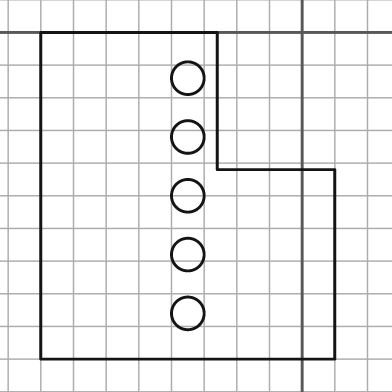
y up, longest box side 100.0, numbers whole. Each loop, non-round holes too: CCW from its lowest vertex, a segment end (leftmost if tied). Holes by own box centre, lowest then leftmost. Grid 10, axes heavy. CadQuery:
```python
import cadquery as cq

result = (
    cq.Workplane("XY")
    .moveTo(-80.0, -100.0)
    .lineTo(10.0, -100.0)
    .lineTo(10.0, -42.0)
    .lineTo(-26.0, -42.0)
    .lineTo(-26.0, 0.0)
    .lineTo(-80.0, 0.0)
    .close()
    .moveTo(-35.0, -86.0)
    .circle(5.0)
    .moveTo(-35.0, -68.0)
    .circle(5.0)
    .moveTo(-35.0, -50.0)
    .circle(5.0)
    .moveTo(-35.0, -32.0)
    .circle(5.0)
    .moveTo(-35.0, -14.0)
    .circle(5.0)
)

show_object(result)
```